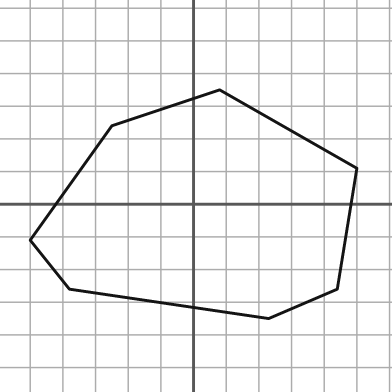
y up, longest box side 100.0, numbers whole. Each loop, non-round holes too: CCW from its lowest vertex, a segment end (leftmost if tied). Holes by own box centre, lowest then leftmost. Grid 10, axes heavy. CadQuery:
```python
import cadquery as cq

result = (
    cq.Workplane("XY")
    .moveTo(23.0, -35.0)
    .lineTo(44.0, -26.0)
    .lineTo(50.0, 11.0)
    .lineTo(8.0, 35.0)
    .lineTo(-25.0, 24.0)
    .lineTo(-50.0, -11.0)
    .lineTo(-38.0, -26.0)
    .close()
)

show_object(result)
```